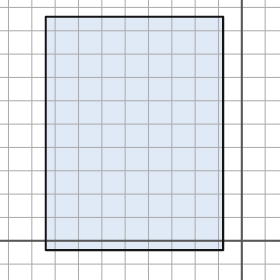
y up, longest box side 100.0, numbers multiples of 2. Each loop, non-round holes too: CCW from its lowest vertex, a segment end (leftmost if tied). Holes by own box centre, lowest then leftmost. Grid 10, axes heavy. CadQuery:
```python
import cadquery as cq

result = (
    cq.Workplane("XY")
    .moveTo(-84.0, -4.0)
    .lineTo(-8.0, -4.0)
    .lineTo(-8.0, 96.0)
    .lineTo(-84.0, 96.0)
    .close()
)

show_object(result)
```